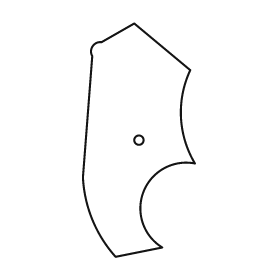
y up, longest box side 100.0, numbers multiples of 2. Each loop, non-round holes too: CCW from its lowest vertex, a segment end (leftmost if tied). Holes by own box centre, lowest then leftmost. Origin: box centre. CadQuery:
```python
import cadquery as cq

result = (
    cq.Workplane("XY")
    .moveTo(-10.0, -50.0)
    .lineTo(10.0, -46.0)
    .threePointArc((2.0, -22.0), (24.0, -10.0))
    .threePointArc((18.0, 10.0), (22.0, 30.0))
    .lineTo(-2.0, 50.0)
    .lineTo(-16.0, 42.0)
    .threePointArc((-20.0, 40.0), (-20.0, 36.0))
    .lineTo(-24.0, -16.0)
    .threePointArc((-20.0, -34.0), (-10.0, -50.0))
    .close()
    .moveTo(0.0, 0.0)
    .circle(2.0)
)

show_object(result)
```